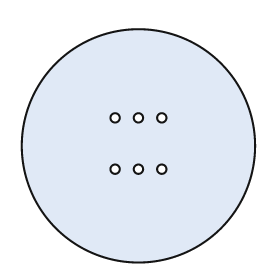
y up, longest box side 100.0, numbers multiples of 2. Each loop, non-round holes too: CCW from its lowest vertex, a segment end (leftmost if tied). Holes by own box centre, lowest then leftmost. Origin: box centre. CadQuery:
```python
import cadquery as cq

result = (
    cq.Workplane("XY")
    .moveTo(0.0, 0.0)
    .circle(50.0)
    .moveTo(-10.0, -10.0)
    .circle(2.0)
    .moveTo(0.0, -10.0)
    .circle(2.0)
    .moveTo(10.0, -10.0)
    .circle(2.0)
    .moveTo(-10.0, 12.0)
    .circle(2.0)
    .moveTo(0.0, 12.0)
    .circle(2.0)
    .moveTo(10.0, 12.0)
    .circle(2.0)
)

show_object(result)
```